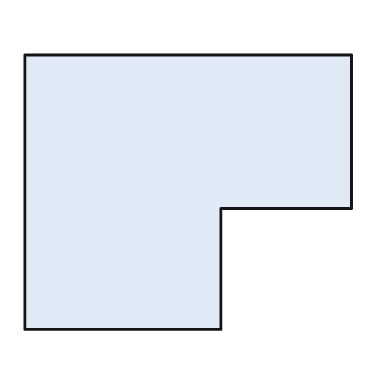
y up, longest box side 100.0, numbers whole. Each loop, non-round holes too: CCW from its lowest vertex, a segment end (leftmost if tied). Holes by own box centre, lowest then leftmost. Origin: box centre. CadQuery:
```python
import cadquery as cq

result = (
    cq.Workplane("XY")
    .moveTo(-50.0, -42.0)
    .lineTo(10.0, -42.0)
    .lineTo(10.0, -5.0)
    .lineTo(50.0, -5.0)
    .lineTo(50.0, 42.0)
    .lineTo(-50.0, 42.0)
    .close()
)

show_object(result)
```